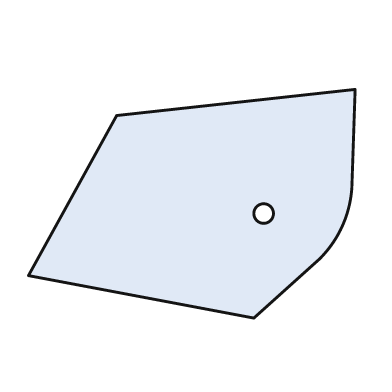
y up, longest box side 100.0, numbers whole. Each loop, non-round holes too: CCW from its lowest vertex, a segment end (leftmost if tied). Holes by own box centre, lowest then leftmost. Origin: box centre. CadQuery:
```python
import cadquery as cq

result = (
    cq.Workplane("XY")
    .moveTo(19.0, -35.0)
    .lineTo(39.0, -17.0)
    .threePointArc((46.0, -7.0), (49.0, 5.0))
    .lineTo(50.0, 35.0)
    .lineTo(-23.0, 27.0)
    .lineTo(-50.0, -22.0)
    .close()
    .moveTo(22.0, -3.0)
    .circle(3.0)
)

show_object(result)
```